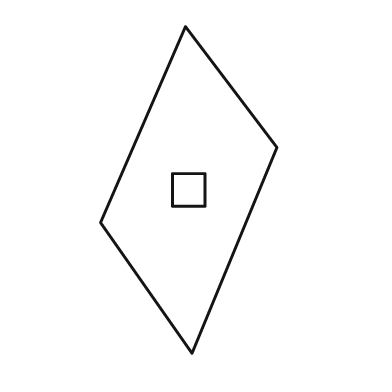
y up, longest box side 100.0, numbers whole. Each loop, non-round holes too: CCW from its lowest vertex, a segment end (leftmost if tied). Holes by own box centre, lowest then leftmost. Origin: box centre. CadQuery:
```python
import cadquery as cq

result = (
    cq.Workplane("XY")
    .moveTo(1.0, -50.0)
    .lineTo(27.0, 13.0)
    .lineTo(-1.0, 50.0)
    .lineTo(-27.0, -10.0)
    .close()
    .moveTo(-5.0, -5.0)
    .lineTo(5.0, -5.0)
    .lineTo(5.0, 5.0)
    .lineTo(-5.0, 5.0)
    .close()
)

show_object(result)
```